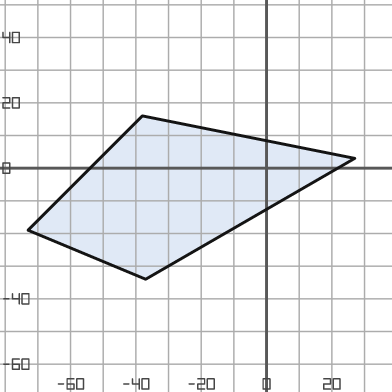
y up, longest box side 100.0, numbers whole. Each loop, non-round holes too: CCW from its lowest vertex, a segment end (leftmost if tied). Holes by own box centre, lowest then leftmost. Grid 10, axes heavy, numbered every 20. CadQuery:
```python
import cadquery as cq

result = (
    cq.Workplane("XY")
    .moveTo(-37.0, -34.0)
    .lineTo(27.0, 3.0)
    .lineTo(-38.0, 16.0)
    .lineTo(-73.0, -19.0)
    .close()
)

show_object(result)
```